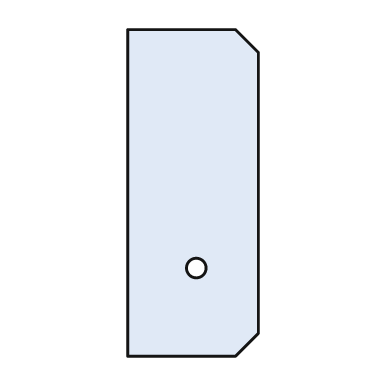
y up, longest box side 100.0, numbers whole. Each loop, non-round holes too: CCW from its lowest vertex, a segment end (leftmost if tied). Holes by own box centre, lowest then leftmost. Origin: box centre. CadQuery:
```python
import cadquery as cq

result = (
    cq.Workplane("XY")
    .moveTo(-20.0, -50.0)
    .lineTo(13.0, -50.0)
    .lineTo(20.0, -43.0)
    .lineTo(20.0, 43.0)
    .lineTo(13.0, 50.0)
    .lineTo(-20.0, 50.0)
    .close()
    .moveTo(1.0, -23.0)
    .circle(3.0)
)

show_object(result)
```